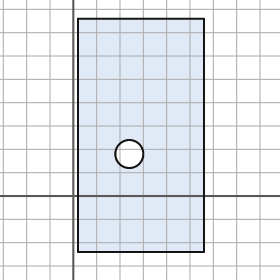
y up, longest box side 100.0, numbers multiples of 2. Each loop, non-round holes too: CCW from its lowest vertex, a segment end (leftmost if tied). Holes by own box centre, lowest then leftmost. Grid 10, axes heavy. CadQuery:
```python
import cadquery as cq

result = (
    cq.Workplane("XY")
    .moveTo(2.0, -24.0)
    .lineTo(56.0, -24.0)
    .lineTo(56.0, 76.0)
    .lineTo(2.0, 76.0)
    .close()
    .moveTo(24.0, 18.0)
    .circle(6.0)
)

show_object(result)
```